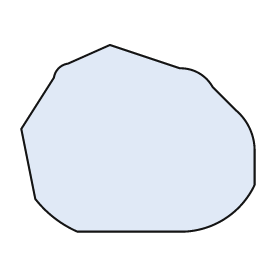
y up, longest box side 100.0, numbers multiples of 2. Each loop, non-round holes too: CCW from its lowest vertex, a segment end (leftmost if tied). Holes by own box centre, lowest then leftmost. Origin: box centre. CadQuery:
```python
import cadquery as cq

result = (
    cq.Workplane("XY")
    .moveTo(-26.0, -40.0)
    .lineTo(20.0, -40.0)
    .threePointArc((38.0, -34.0), (50.0, -20.0))
    .lineTo(50.0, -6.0)
    .threePointArc((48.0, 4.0), (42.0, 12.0))
    .lineTo(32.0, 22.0)
    .threePointArc((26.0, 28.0), (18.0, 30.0))
    .lineTo(-12.0, 40.0)
    .lineTo(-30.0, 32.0)
    .threePointArc((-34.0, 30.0), (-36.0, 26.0))
    .lineTo(-50.0, 4.0)
    .lineTo(-44.0, -26.0)
    .threePointArc((-36.0, -34.0), (-26.0, -40.0))
    .close()
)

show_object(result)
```